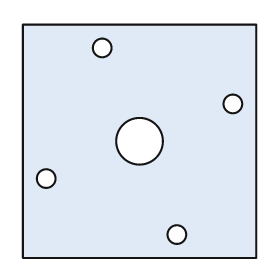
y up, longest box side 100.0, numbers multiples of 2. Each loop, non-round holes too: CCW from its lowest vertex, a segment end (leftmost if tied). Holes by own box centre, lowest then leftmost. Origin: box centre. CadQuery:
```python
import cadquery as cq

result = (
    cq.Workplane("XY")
    .moveTo(-50.0, -50.0)
    .lineTo(50.0, -50.0)
    .lineTo(50.0, 50.0)
    .lineTo(-50.0, 50.0)
    .close()
    .moveTo(16.0, -40.0)
    .circle(4.0)
    .moveTo(-40.0, -16.0)
    .circle(4.0)
    .moveTo(0.0, 0.0)
    .circle(10.0)
    .moveTo(40.0, 16.0)
    .circle(4.0)
    .moveTo(-16.0, 40.0)
    .circle(4.0)
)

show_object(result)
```